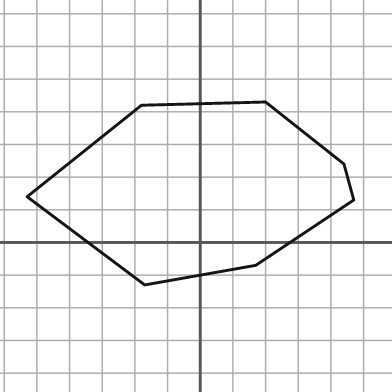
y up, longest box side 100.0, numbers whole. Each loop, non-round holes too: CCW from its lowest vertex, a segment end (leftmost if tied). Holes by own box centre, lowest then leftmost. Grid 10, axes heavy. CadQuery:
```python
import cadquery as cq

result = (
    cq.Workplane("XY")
    .moveTo(-17.0, -13.0)
    .lineTo(17.0, -7.0)
    .lineTo(47.0, 13.0)
    .lineTo(44.0, 24.0)
    .lineTo(20.0, 43.0)
    .lineTo(-18.0, 42.0)
    .lineTo(-53.0, 14.0)
    .close()
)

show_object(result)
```